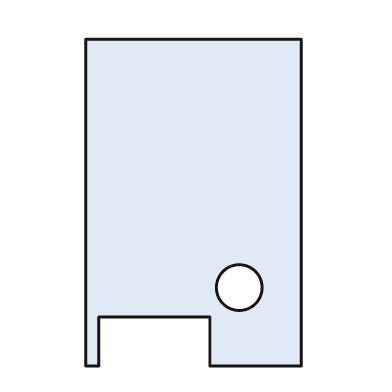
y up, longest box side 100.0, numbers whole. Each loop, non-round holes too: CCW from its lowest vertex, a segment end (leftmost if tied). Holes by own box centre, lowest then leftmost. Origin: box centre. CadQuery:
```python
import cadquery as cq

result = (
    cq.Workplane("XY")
    .moveTo(-33.0, -50.0)
    .lineTo(-29.0, -50.0)
    .lineTo(-29.0, -35.0)
    .lineTo(5.0, -35.0)
    .lineTo(5.0, -50.0)
    .lineTo(33.0, -50.0)
    .lineTo(33.0, 50.0)
    .lineTo(-33.0, 50.0)
    .close()
    .moveTo(14.0, -26.0)
    .circle(7.0)
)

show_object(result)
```